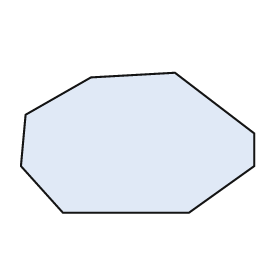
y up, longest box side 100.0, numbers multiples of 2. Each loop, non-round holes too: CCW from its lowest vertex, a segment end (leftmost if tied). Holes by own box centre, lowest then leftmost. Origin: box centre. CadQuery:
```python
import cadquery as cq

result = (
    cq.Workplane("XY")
    .moveTo(-32.0, -30.0)
    .lineTo(22.0, -30.0)
    .lineTo(50.0, -10.0)
    .lineTo(50.0, 4.0)
    .lineTo(16.0, 30.0)
    .lineTo(-20.0, 28.0)
    .lineTo(-48.0, 12.0)
    .lineTo(-50.0, -10.0)
    .close()
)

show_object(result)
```